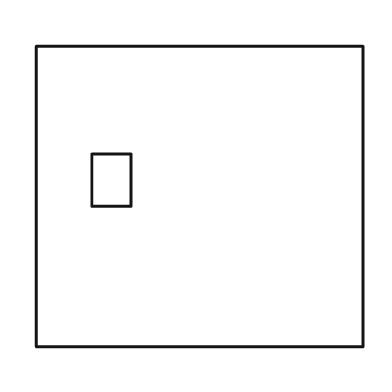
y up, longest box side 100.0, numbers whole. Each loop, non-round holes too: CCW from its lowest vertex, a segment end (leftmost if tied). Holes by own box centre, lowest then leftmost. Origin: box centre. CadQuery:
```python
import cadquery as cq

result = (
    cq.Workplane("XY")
    .moveTo(-50.0, -46.0)
    .lineTo(50.0, -46.0)
    .lineTo(50.0, 46.0)
    .lineTo(-50.0, 46.0)
    .close()
    .moveTo(-33.0, -3.0)
    .lineTo(-21.0, -3.0)
    .lineTo(-21.0, 13.0)
    .lineTo(-33.0, 13.0)
    .close()
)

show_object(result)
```